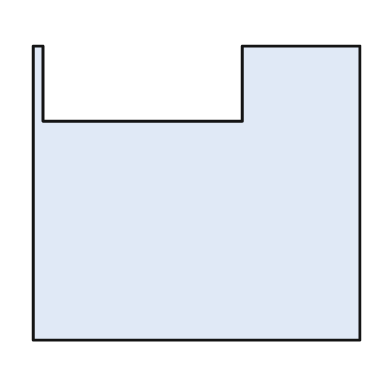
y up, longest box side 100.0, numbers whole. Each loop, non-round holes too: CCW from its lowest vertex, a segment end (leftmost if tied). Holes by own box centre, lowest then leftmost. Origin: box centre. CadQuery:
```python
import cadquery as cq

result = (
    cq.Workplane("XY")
    .moveTo(-50.0, -45.0)
    .lineTo(50.0, -45.0)
    .lineTo(50.0, 45.0)
    .lineTo(14.0, 45.0)
    .lineTo(14.0, 22.0)
    .lineTo(-47.0, 22.0)
    .lineTo(-47.0, 45.0)
    .lineTo(-50.0, 45.0)
    .close()
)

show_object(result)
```